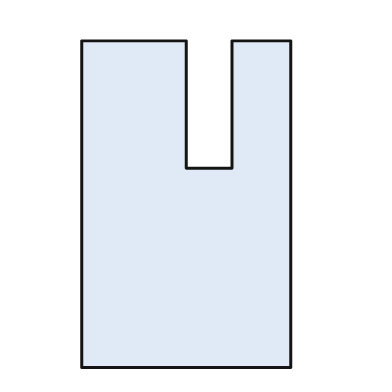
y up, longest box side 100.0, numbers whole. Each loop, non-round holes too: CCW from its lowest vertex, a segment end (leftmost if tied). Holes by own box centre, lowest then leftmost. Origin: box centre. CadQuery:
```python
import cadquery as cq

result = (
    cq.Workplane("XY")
    .moveTo(-32.0, -50.0)
    .lineTo(32.0, -50.0)
    .lineTo(32.0, 50.0)
    .lineTo(14.0, 50.0)
    .lineTo(14.0, 11.0)
    .lineTo(0.0, 11.0)
    .lineTo(0.0, 50.0)
    .lineTo(-32.0, 50.0)
    .close()
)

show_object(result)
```